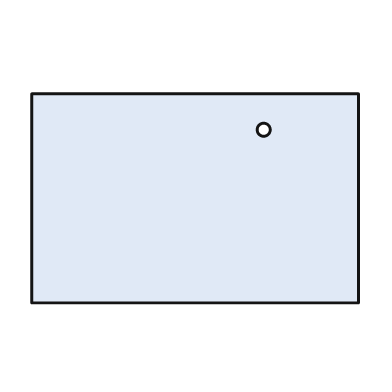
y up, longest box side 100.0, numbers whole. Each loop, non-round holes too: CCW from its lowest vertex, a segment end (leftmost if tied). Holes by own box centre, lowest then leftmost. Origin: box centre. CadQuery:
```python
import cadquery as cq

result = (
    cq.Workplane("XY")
    .moveTo(-50.0, -32.0)
    .lineTo(50.0, -32.0)
    .lineTo(50.0, 32.0)
    .lineTo(-50.0, 32.0)
    .close()
    .moveTo(21.0, 21.0)
    .circle(2.0)
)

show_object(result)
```